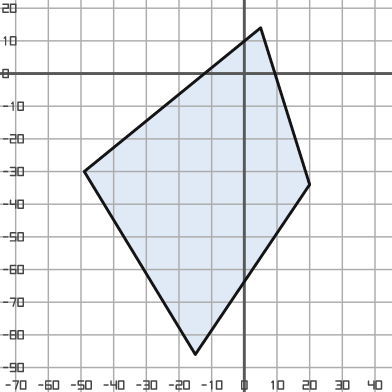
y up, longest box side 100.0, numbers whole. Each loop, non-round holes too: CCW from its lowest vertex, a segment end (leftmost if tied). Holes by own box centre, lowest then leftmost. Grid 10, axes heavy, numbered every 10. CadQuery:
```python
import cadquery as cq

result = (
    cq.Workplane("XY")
    .moveTo(-15.0, -86.0)
    .lineTo(20.0, -34.0)
    .lineTo(5.0, 14.0)
    .lineTo(-49.0, -30.0)
    .close()
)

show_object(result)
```